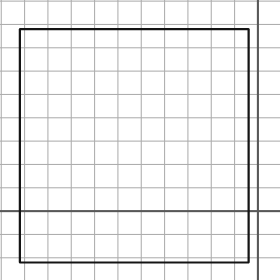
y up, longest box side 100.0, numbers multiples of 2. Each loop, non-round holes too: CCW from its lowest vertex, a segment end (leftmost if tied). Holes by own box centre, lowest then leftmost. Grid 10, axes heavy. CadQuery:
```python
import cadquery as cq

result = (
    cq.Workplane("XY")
    .moveTo(-102.0, -22.0)
    .lineTo(-4.0, -22.0)
    .lineTo(-4.0, 78.0)
    .lineTo(-102.0, 78.0)
    .close()
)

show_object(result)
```